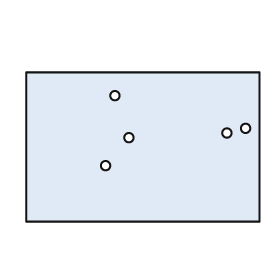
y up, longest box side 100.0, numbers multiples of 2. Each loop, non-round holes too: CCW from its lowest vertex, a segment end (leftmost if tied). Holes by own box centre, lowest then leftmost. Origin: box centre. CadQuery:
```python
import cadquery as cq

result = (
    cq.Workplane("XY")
    .moveTo(-50.0, -32.0)
    .lineTo(50.0, -32.0)
    .lineTo(50.0, 32.0)
    .lineTo(-50.0, 32.0)
    .close()
    .moveTo(-16.0, -8.0)
    .circle(2.0)
    .moveTo(-6.0, 4.0)
    .circle(2.0)
    .moveTo(36.0, 6.0)
    .circle(2.0)
    .moveTo(44.0, 8.0)
    .circle(2.0)
    .moveTo(-12.0, 22.0)
    .circle(2.0)
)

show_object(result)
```